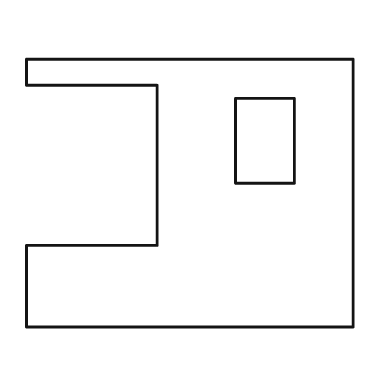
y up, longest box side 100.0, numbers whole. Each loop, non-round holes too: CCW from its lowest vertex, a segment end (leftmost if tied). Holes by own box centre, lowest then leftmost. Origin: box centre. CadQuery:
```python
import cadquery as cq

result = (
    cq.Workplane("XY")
    .moveTo(-50.0, -41.0)
    .lineTo(50.0, -41.0)
    .lineTo(50.0, 41.0)
    .lineTo(-50.0, 41.0)
    .lineTo(-50.0, 33.0)
    .lineTo(-10.0, 33.0)
    .lineTo(-10.0, -16.0)
    .lineTo(-50.0, -16.0)
    .close()
    .moveTo(14.0, 3.0)
    .lineTo(32.0, 3.0)
    .lineTo(32.0, 29.0)
    .lineTo(14.0, 29.0)
    .close()
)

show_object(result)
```